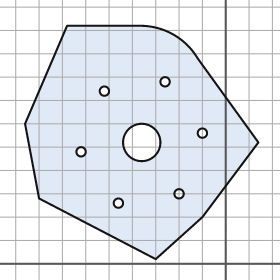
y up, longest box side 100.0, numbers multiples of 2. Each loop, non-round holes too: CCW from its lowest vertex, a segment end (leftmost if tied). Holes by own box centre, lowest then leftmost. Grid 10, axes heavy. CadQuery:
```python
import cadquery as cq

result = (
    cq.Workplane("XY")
    .moveTo(-30.0, 2.0)
    .lineTo(-10.0, 20.0)
    .lineTo(14.0, 52.0)
    .lineTo(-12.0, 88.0)
    .threePointArc((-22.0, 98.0), (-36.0, 102.0))
    .lineTo(-68.0, 102.0)
    .lineTo(-86.0, 60.0)
    .lineTo(-80.0, 28.0)
    .close()
    .moveTo(-46.0, 26.0)
    .circle(2.0)
    .moveTo(-20.0, 30.0)
    .circle(2.0)
    .moveTo(-62.0, 48.0)
    .circle(2.0)
    .moveTo(-36.0, 52.0)
    .circle(8.0)
    .moveTo(-10.0, 56.0)
    .circle(2.0)
    .moveTo(-52.0, 74.0)
    .circle(2.0)
    .moveTo(-26.0, 78.0)
    .circle(2.0)
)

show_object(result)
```